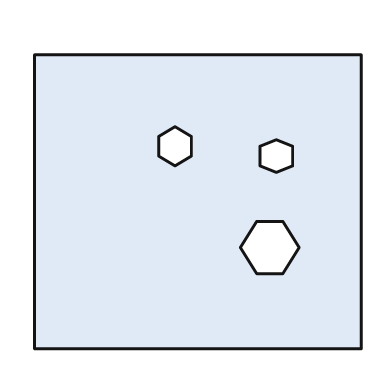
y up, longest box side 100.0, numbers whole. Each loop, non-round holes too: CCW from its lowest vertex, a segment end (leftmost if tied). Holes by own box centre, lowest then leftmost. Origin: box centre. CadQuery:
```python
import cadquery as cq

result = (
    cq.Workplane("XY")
    .moveTo(-50.0, -45.0)
    .lineTo(50.0, -45.0)
    .lineTo(50.0, 45.0)
    .lineTo(-50.0, 45.0)
    .close()
    .moveTo(18.0, -22.0)
    .lineTo(26.0, -22.0)
    .lineTo(31.0, -14.0)
    .lineTo(26.0, -6.0)
    .lineTo(18.0, -6.0)
    .lineTo(13.0, -14.0)
    .close()
    .moveTo(24.0, 9.0)
    .lineTo(29.0, 11.0)
    .lineTo(29.0, 17.0)
    .lineTo(24.0, 19.0)
    .lineTo(19.0, 17.0)
    .lineTo(19.0, 11.0)
    .close()
    .moveTo(-7.0, 11.0)
    .lineTo(-2.0, 14.0)
    .lineTo(-2.0, 20.0)
    .lineTo(-7.0, 23.0)
    .lineTo(-12.0, 20.0)
    .lineTo(-12.0, 14.0)
    .close()
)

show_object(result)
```